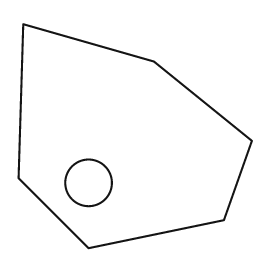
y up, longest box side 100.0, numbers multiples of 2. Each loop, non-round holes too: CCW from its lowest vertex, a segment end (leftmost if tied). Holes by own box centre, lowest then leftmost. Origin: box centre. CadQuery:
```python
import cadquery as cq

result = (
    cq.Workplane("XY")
    .moveTo(-20.0, -48.0)
    .lineTo(38.0, -36.0)
    .lineTo(50.0, -2.0)
    .lineTo(8.0, 32.0)
    .lineTo(-48.0, 48.0)
    .lineTo(-50.0, -18.0)
    .close()
    .moveTo(-20.0, -20.0)
    .circle(10.0)
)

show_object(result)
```